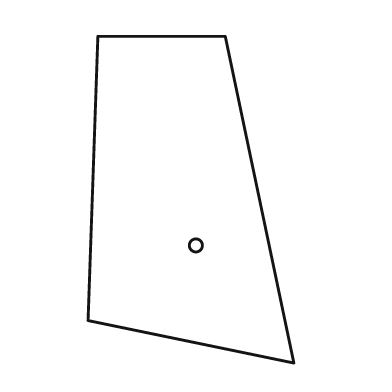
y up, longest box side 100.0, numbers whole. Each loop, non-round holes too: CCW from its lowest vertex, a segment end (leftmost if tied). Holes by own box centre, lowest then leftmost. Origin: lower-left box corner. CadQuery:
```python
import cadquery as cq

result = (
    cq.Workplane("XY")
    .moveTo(63.0, 0.0)
    .lineTo(42.0, 100.0)
    .lineTo(3.0, 100.0)
    .lineTo(0.0, 13.0)
    .close()
    .moveTo(33.0, 36.0)
    .circle(2.0)
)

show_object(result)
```